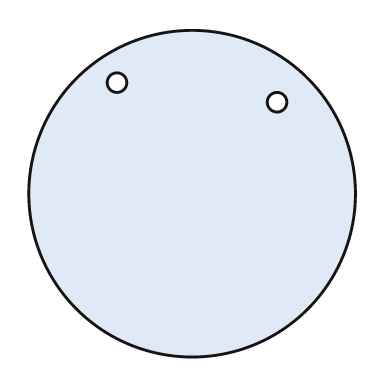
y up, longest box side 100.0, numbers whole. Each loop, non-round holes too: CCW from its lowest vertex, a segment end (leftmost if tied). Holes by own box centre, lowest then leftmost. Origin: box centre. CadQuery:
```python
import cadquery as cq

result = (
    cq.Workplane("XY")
    .moveTo(0.0, 0.0)
    .circle(50.0)
    .moveTo(26.0, 28.0)
    .circle(3.0)
    .moveTo(-23.0, 34.0)
    .circle(3.0)
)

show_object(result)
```